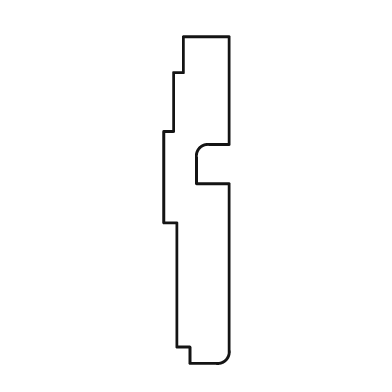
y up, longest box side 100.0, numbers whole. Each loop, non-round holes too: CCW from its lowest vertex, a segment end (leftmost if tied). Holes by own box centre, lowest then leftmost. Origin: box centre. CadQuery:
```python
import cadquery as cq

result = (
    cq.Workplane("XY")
    .moveTo(-2.0, -50.0)
    .lineTo(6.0, -50.0)
    .threePointArc((9.0, -49.0), (10.0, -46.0))
    .lineTo(10.0, 5.0)
    .lineTo(0.0, 5.0)
    .lineTo(0.0, 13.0)
    .threePointArc((1.0, 16.0), (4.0, 17.0))
    .lineTo(10.0, 17.0)
    .lineTo(10.0, 50.0)
    .lineTo(-4.0, 50.0)
    .lineTo(-4.0, 39.0)
    .lineTo(-7.0, 39.0)
    .lineTo(-7.0, 21.0)
    .lineTo(-10.0, 21.0)
    .lineTo(-10.0, -7.0)
    .lineTo(-6.0, -7.0)
    .lineTo(-6.0, -45.0)
    .lineTo(-2.0, -45.0)
    .close()
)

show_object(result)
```